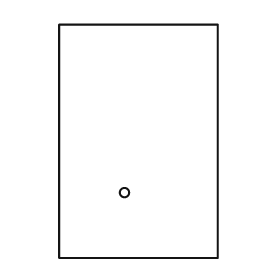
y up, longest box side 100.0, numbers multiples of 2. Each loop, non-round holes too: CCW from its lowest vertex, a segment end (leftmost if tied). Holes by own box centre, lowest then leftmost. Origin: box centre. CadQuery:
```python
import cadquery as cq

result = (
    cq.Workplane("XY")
    .moveTo(-34.0, -50.0)
    .lineTo(34.0, -50.0)
    .lineTo(34.0, 50.0)
    .lineTo(-34.0, 50.0)
    .close()
    .moveTo(-6.0, -22.0)
    .circle(2.0)
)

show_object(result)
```